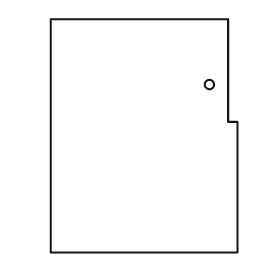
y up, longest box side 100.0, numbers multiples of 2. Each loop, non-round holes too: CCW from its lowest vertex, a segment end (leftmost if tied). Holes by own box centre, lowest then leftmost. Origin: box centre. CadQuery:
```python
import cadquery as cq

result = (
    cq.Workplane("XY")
    .moveTo(-40.0, -50.0)
    .lineTo(40.0, -50.0)
    .lineTo(40.0, 6.0)
    .lineTo(36.0, 6.0)
    .lineTo(36.0, 50.0)
    .lineTo(-40.0, 50.0)
    .close()
    .moveTo(28.0, 22.0)
    .circle(2.0)
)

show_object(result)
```